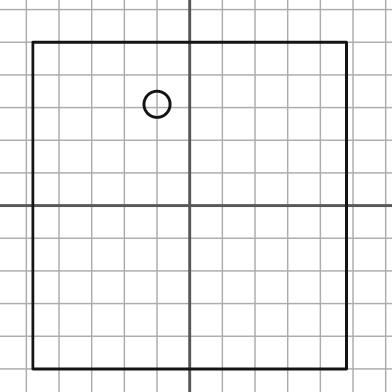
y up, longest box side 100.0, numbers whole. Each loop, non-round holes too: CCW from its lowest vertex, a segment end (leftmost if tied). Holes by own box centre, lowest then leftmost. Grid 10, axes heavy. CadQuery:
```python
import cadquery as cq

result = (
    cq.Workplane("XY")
    .moveTo(-48.0, -50.0)
    .lineTo(48.0, -50.0)
    .lineTo(48.0, 50.0)
    .lineTo(-48.0, 50.0)
    .close()
    .moveTo(-10.0, 31.0)
    .circle(4.0)
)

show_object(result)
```